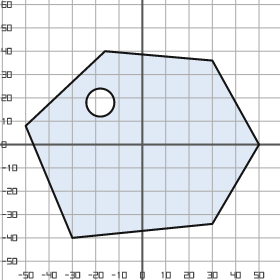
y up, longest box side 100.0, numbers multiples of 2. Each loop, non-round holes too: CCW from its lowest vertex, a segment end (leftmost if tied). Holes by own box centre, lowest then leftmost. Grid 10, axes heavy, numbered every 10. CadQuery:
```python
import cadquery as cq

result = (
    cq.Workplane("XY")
    .moveTo(-30.0, -40.0)
    .lineTo(30.0, -34.0)
    .lineTo(50.0, 0.0)
    .lineTo(30.0, 36.0)
    .lineTo(-16.0, 40.0)
    .lineTo(-50.0, 8.0)
    .close()
    .moveTo(-18.0, 18.0)
    .circle(6.0)
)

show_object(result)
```